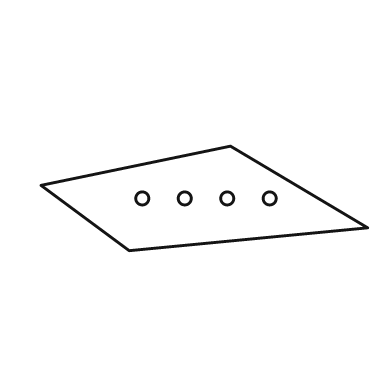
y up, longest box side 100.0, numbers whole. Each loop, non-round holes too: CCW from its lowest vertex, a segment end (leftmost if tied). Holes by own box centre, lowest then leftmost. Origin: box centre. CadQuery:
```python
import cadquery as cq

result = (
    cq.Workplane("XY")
    .moveTo(-23.0, -16.0)
    .lineTo(50.0, -9.0)
    .lineTo(8.0, 16.0)
    .lineTo(-50.0, 4.0)
    .close()
    .moveTo(-19.0, 0.0)
    .circle(2.0)
    .moveTo(-6.0, 0.0)
    .circle(2.0)
    .moveTo(7.0, 0.0)
    .circle(2.0)
    .moveTo(20.0, 0.0)
    .circle(2.0)
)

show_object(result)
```